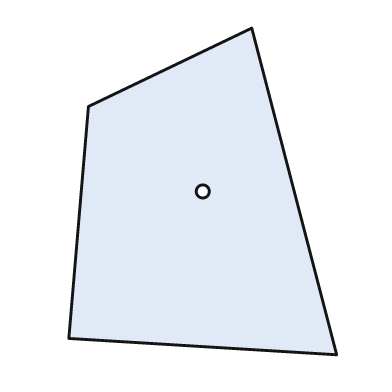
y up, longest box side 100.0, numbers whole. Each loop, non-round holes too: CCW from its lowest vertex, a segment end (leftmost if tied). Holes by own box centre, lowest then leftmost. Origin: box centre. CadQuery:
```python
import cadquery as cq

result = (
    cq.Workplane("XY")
    .moveTo(41.0, -50.0)
    .lineTo(15.0, 50.0)
    .lineTo(-35.0, 26.0)
    .lineTo(-41.0, -45.0)
    .close()
    .moveTo(0.0, 0.0)
    .circle(2.0)
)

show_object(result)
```